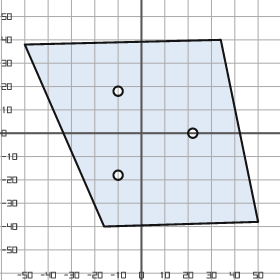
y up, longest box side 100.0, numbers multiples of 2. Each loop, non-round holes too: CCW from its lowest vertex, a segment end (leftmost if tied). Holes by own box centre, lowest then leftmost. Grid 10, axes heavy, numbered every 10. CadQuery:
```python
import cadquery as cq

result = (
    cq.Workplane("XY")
    .moveTo(-16.0, -40.0)
    .lineTo(50.0, -38.0)
    .lineTo(34.0, 40.0)
    .lineTo(-50.0, 38.0)
    .close()
    .moveTo(-10.0, -18.0)
    .circle(2.0)
    .moveTo(22.0, 0.0)
    .circle(2.0)
    .moveTo(-10.0, 18.0)
    .circle(2.0)
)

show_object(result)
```